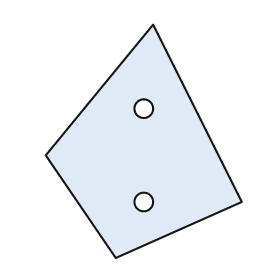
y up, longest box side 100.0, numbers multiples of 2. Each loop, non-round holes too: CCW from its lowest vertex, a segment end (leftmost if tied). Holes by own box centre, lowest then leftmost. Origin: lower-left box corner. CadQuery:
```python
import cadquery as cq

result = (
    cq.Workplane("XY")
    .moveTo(30.0, 0.0)
    .lineTo(84.0, 24.0)
    .lineTo(46.0, 100.0)
    .lineTo(0.0, 44.0)
    .close()
    .moveTo(42.0, 24.0)
    .circle(4.0)
    .moveTo(42.0, 64.0)
    .circle(4.0)
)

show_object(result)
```